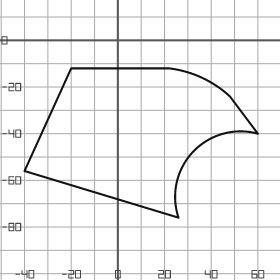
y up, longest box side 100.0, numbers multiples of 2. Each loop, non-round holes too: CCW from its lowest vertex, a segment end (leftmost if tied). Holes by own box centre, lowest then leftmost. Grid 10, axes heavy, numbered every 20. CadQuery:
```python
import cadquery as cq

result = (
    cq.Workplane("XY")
    .moveTo(26.0, -76.0)
    .threePointArc((32.0, -48.0), (60.0, -40.0))
    .lineTo(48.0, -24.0)
    .threePointArc((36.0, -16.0), (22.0, -12.0))
    .lineTo(-20.0, -12.0)
    .lineTo(-40.0, -56.0)
    .close()
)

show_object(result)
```